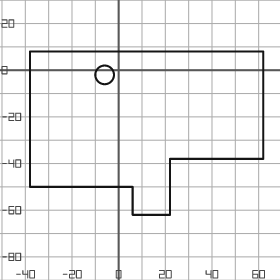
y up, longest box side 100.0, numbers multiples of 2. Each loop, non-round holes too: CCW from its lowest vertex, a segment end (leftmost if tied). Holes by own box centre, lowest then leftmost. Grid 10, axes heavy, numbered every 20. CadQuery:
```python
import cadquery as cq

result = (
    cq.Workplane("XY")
    .moveTo(6.0, -62.0)
    .lineTo(22.0, -62.0)
    .lineTo(22.0, -38.0)
    .lineTo(62.0, -38.0)
    .lineTo(62.0, 8.0)
    .lineTo(-38.0, 8.0)
    .lineTo(-38.0, -50.0)
    .lineTo(6.0, -50.0)
    .close()
    .moveTo(-6.0, -2.0)
    .circle(4.0)
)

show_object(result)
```